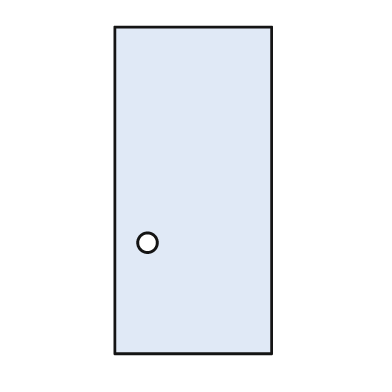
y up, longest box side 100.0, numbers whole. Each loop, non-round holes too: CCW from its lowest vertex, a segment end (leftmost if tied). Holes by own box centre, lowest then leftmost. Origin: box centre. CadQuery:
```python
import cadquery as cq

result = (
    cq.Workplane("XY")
    .moveTo(-24.0, -50.0)
    .lineTo(24.0, -50.0)
    .lineTo(24.0, 50.0)
    .lineTo(-24.0, 50.0)
    .close()
    .moveTo(-14.0, -16.0)
    .circle(3.0)
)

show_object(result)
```